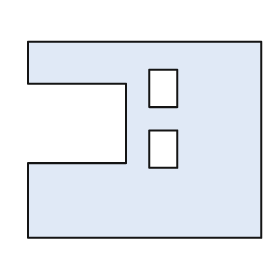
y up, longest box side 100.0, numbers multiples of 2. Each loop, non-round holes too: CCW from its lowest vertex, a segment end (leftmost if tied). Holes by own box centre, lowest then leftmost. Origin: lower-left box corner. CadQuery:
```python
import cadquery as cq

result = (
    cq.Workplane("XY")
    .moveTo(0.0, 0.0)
    .lineTo(100.0, 0.0)
    .lineTo(100.0, 84.0)
    .lineTo(0.0, 84.0)
    .lineTo(0.0, 66.0)
    .lineTo(42.0, 66.0)
    .lineTo(42.0, 32.0)
    .lineTo(0.0, 32.0)
    .close()
    .moveTo(52.0, 30.0)
    .lineTo(64.0, 30.0)
    .lineTo(64.0, 46.0)
    .lineTo(52.0, 46.0)
    .close()
    .moveTo(52.0, 56.0)
    .lineTo(64.0, 56.0)
    .lineTo(64.0, 72.0)
    .lineTo(52.0, 72.0)
    .close()
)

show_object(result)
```